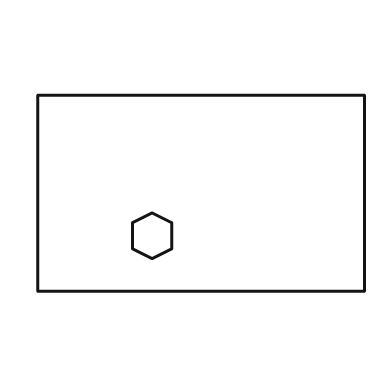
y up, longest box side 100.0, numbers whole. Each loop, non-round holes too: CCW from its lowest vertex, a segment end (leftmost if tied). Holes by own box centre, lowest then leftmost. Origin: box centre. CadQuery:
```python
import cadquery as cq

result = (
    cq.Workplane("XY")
    .moveTo(-50.0, -30.0)
    .lineTo(50.0, -30.0)
    .lineTo(50.0, 30.0)
    .lineTo(-50.0, 30.0)
    .close()
    .moveTo(-15.0, -20.0)
    .lineTo(-9.0, -17.0)
    .lineTo(-9.0, -9.0)
    .lineTo(-15.0, -6.0)
    .lineTo(-21.0, -9.0)
    .lineTo(-21.0, -17.0)
    .close()
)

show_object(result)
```